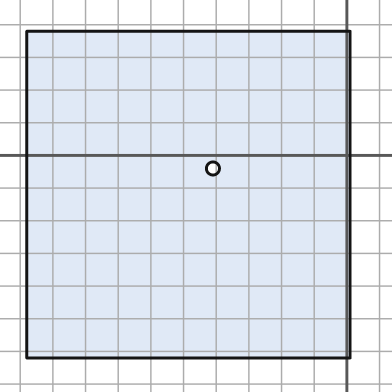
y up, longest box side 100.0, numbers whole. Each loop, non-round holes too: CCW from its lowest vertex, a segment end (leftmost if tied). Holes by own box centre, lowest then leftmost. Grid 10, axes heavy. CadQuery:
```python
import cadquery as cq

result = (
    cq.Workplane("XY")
    .moveTo(-98.0, -62.0)
    .lineTo(1.0, -62.0)
    .lineTo(1.0, 38.0)
    .lineTo(-98.0, 38.0)
    .close()
    .moveTo(-41.0, -4.0)
    .circle(2.0)
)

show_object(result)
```